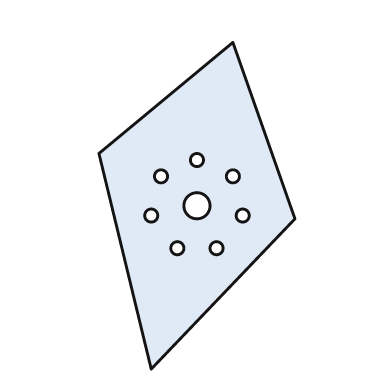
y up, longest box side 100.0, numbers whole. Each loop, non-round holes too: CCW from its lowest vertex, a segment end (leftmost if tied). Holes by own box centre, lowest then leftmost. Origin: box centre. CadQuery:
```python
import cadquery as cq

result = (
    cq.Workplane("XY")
    .moveTo(-14.0, -50.0)
    .lineTo(30.0, -4.0)
    .lineTo(11.0, 50.0)
    .lineTo(-30.0, 16.0)
    .close()
    .moveTo(-6.0, -13.0)
    .circle(2.0)
    .moveTo(6.0, -13.0)
    .circle(2.0)
    .moveTo(-14.0, -3.0)
    .circle(2.0)
    .moveTo(14.0, -3.0)
    .circle(2.0)
    .moveTo(0.0, 0.0)
    .circle(4.0)
    .moveTo(-11.0, 9.0)
    .circle(2.0)
    .moveTo(11.0, 9.0)
    .circle(2.0)
    .moveTo(0.0, 14.0)
    .circle(2.0)
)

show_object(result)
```